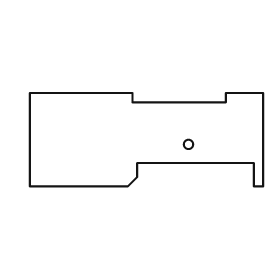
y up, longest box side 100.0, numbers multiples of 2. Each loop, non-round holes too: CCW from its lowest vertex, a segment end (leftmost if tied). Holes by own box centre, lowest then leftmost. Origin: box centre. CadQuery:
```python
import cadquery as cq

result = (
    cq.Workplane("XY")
    .moveTo(-50.0, -20.0)
    .lineTo(-8.0, -20.0)
    .lineTo(-4.0, -16.0)
    .lineTo(-4.0, -10.0)
    .lineTo(46.0, -10.0)
    .lineTo(46.0, -20.0)
    .lineTo(50.0, -20.0)
    .lineTo(50.0, 20.0)
    .lineTo(34.0, 20.0)
    .lineTo(34.0, 16.0)
    .lineTo(-6.0, 16.0)
    .lineTo(-6.0, 20.0)
    .lineTo(-50.0, 20.0)
    .close()
    .moveTo(18.0, -2.0)
    .circle(2.0)
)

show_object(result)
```